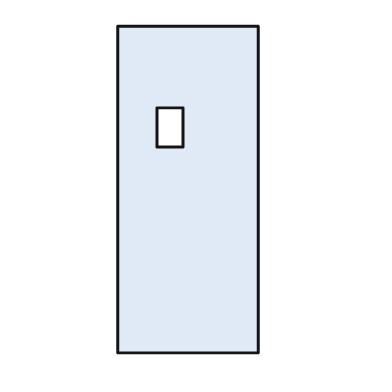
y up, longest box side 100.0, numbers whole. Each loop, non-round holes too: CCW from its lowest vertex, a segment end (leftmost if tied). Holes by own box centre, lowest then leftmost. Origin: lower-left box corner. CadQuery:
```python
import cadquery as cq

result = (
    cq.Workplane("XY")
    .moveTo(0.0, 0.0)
    .lineTo(43.0, 0.0)
    .lineTo(43.0, 100.0)
    .lineTo(0.0, 100.0)
    .close()
    .moveTo(12.0, 63.0)
    .lineTo(20.0, 63.0)
    .lineTo(20.0, 75.0)
    .lineTo(12.0, 75.0)
    .close()
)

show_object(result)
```